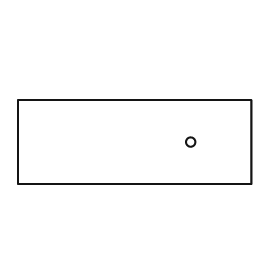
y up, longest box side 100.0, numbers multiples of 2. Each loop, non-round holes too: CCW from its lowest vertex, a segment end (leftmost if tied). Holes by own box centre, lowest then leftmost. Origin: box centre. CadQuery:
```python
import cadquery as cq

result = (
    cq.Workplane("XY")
    .moveTo(-50.0, -18.0)
    .lineTo(50.0, -18.0)
    .lineTo(50.0, 18.0)
    .lineTo(-50.0, 18.0)
    .close()
    .moveTo(24.0, 0.0)
    .circle(2.0)
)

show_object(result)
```